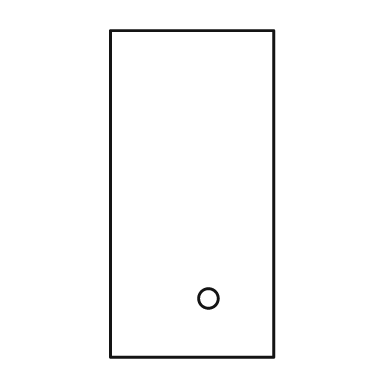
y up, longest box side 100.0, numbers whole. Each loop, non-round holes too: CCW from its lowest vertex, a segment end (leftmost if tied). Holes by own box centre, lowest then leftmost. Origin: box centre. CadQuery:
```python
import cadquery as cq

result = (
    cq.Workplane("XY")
    .moveTo(-25.0, -50.0)
    .lineTo(25.0, -50.0)
    .lineTo(25.0, 50.0)
    .lineTo(-25.0, 50.0)
    .close()
    .moveTo(5.0, -32.0)
    .circle(3.0)
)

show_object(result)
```